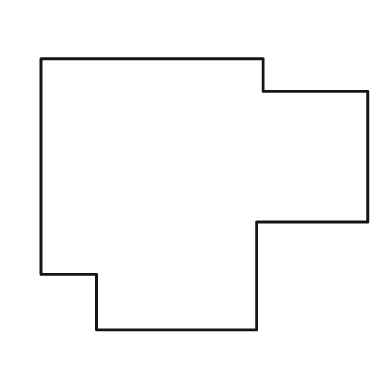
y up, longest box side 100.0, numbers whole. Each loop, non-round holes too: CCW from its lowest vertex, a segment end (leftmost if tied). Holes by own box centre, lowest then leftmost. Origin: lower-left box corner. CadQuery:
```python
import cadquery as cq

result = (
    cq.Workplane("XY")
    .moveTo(17.0, 0.0)
    .lineTo(66.0, 0.0)
    .lineTo(66.0, 33.0)
    .lineTo(100.0, 33.0)
    .lineTo(100.0, 73.0)
    .lineTo(68.0, 73.0)
    .lineTo(68.0, 83.0)
    .lineTo(0.0, 83.0)
    .lineTo(0.0, 17.0)
    .lineTo(17.0, 17.0)
    .close()
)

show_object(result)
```